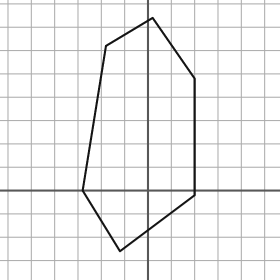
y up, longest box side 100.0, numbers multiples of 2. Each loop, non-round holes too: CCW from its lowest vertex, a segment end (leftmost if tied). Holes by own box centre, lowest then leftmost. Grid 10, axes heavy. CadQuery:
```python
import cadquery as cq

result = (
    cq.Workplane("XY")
    .moveTo(-12.0, -26.0)
    .lineTo(20.0, -2.0)
    .lineTo(20.0, 48.0)
    .lineTo(2.0, 74.0)
    .lineTo(-18.0, 62.0)
    .lineTo(-28.0, 0.0)
    .close()
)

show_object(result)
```